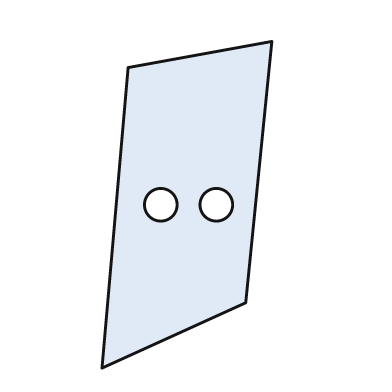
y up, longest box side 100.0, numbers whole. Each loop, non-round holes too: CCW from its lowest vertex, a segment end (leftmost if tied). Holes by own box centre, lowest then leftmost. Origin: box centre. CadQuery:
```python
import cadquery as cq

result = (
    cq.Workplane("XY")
    .moveTo(-26.0, -50.0)
    .lineTo(18.0, -30.0)
    .lineTo(26.0, 50.0)
    .lineTo(-18.0, 42.0)
    .close()
    .moveTo(-8.0, 0.0)
    .circle(5.0)
    .moveTo(9.0, 0.0)
    .circle(5.0)
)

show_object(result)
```